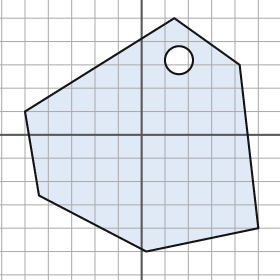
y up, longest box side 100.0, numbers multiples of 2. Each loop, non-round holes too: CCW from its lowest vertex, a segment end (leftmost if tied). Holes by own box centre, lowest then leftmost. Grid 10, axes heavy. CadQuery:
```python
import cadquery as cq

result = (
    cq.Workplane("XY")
    .moveTo(2.0, -50.0)
    .lineTo(50.0, -40.0)
    .lineTo(42.0, 30.0)
    .lineTo(14.0, 50.0)
    .lineTo(-50.0, 10.0)
    .lineTo(-44.0, -26.0)
    .close()
    .moveTo(16.0, 32.0)
    .circle(6.0)
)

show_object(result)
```